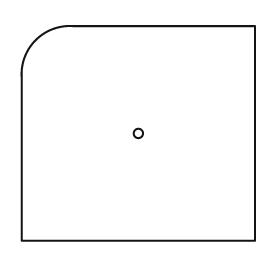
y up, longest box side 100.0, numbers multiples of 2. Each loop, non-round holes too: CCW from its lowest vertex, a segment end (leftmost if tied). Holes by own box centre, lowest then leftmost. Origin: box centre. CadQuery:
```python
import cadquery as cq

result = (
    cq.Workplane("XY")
    .moveTo(-50.0, -46.0)
    .lineTo(50.0, -46.0)
    .lineTo(50.0, 46.0)
    .lineTo(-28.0, 46.0)
    .threePointArc((-44.0, 40.0), (-50.0, 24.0))
    .close()
    .moveTo(0.0, 0.0)
    .circle(2.0)
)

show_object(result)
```